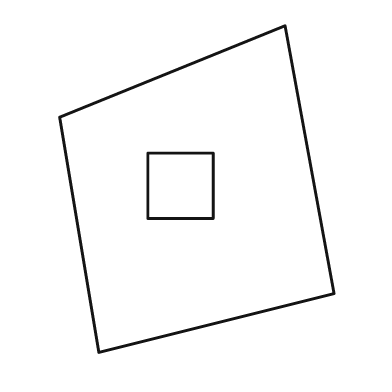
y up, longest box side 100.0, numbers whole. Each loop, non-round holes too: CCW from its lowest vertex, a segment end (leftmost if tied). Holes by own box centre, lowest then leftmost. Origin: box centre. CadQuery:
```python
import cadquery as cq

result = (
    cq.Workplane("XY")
    .moveTo(-30.0, -50.0)
    .lineTo(42.0, -32.0)
    .lineTo(27.0, 50.0)
    .lineTo(-42.0, 22.0)
    .close()
    .moveTo(-15.0, -9.0)
    .lineTo(5.0, -9.0)
    .lineTo(5.0, 11.0)
    .lineTo(-15.0, 11.0)
    .close()
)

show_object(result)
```